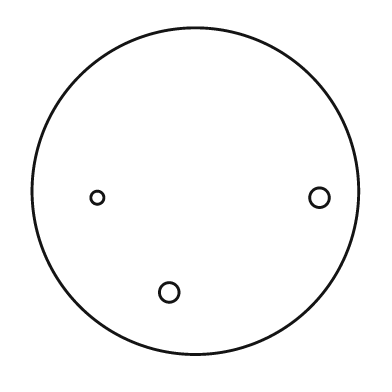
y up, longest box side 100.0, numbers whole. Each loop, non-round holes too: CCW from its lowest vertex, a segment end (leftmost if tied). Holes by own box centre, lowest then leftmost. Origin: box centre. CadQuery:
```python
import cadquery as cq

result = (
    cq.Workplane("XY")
    .moveTo(0.0, 0.0)
    .circle(50.0)
    .moveTo(-8.0, -31.0)
    .circle(3.0)
    .moveTo(-30.0, -2.0)
    .circle(2.0)
    .moveTo(38.0, -2.0)
    .circle(3.0)
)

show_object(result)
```